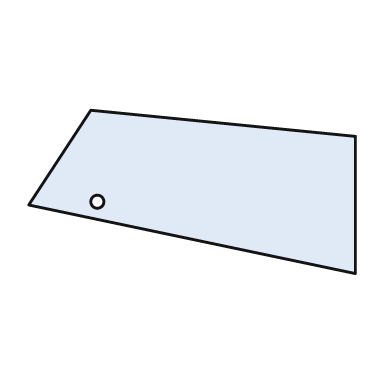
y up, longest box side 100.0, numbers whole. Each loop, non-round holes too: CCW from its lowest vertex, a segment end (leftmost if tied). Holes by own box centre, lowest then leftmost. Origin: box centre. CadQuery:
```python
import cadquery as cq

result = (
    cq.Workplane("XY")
    .moveTo(50.0, -25.0)
    .lineTo(50.0, 17.0)
    .lineTo(-31.0, 25.0)
    .lineTo(-50.0, -4.0)
    .close()
    .moveTo(-29.0, -3.0)
    .circle(2.0)
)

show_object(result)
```